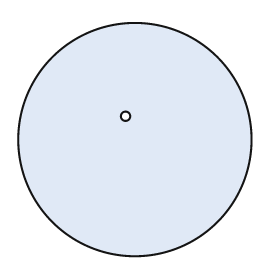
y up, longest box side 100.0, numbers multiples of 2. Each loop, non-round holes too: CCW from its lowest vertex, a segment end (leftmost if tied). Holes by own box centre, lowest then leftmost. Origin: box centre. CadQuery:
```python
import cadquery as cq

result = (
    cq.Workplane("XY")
    .moveTo(0.0, 0.0)
    .circle(50.0)
    .moveTo(-4.0, 10.0)
    .circle(2.0)
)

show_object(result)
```